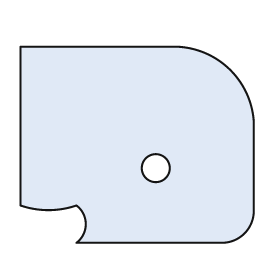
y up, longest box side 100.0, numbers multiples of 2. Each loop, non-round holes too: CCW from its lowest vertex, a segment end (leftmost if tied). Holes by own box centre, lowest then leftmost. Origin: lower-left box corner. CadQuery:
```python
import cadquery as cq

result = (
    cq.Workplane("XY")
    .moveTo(24.0, 0.0)
    .lineTo(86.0, 0.0)
    .threePointArc((96.0, 4.0), (100.0, 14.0))
    .lineTo(100.0, 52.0)
    .threePointArc((90.0, 74.0), (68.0, 84.0))
    .lineTo(0.0, 84.0)
    .lineTo(0.0, 16.0)
    .threePointArc((12.0, 14.0), (24.0, 16.0))
    .threePointArc((28.0, 8.0), (24.0, 0.0))
    .close()
    .moveTo(58.0, 32.0)
    .circle(6.0)
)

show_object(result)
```